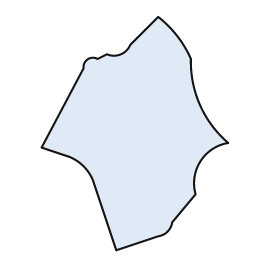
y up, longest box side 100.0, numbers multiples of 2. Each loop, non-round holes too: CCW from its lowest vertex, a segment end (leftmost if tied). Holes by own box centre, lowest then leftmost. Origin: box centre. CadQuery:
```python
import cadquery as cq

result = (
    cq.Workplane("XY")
    .moveTo(-8.0, -50.0)
    .lineTo(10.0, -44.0)
    .threePointArc((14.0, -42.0), (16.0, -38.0))
    .lineTo(26.0, -26.0)
    .threePointArc((28.0, -12.0), (40.0, -4.0))
    .threePointArc((28.0, 12.0), (24.0, 32.0))
    .threePointArc((18.0, 42.0), (10.0, 50.0))
    .lineTo(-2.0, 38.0)
    .threePointArc((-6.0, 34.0), (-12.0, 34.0))
    .lineTo(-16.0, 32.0)
    .threePointArc((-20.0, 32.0), (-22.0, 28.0))
    .lineTo(-40.0, -6.0)
    .lineTo(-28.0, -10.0)
    .threePointArc((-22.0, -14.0), (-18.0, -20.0))
    .close()
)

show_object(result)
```